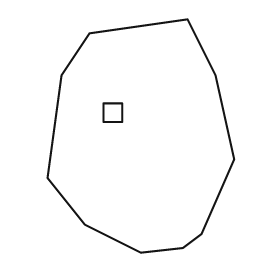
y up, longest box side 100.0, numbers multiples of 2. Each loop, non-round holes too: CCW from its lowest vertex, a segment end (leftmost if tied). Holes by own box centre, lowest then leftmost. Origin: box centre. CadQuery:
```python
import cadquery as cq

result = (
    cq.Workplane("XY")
    .moveTo(0.0, -50.0)
    .lineTo(18.0, -48.0)
    .lineTo(26.0, -42.0)
    .lineTo(40.0, -10.0)
    .lineTo(32.0, 26.0)
    .lineTo(20.0, 50.0)
    .lineTo(-22.0, 44.0)
    .lineTo(-34.0, 26.0)
    .lineTo(-40.0, -18.0)
    .lineTo(-24.0, -38.0)
    .close()
    .moveTo(-16.0, 6.0)
    .lineTo(-8.0, 6.0)
    .lineTo(-8.0, 14.0)
    .lineTo(-16.0, 14.0)
    .close()
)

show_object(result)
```